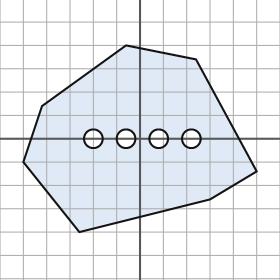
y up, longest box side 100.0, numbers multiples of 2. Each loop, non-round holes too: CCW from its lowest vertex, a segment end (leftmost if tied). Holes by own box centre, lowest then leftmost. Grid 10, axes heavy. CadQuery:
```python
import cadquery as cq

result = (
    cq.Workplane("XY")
    .moveTo(-26.0, -40.0)
    .lineTo(30.0, -26.0)
    .lineTo(50.0, -14.0)
    .lineTo(24.0, 34.0)
    .lineTo(-6.0, 40.0)
    .lineTo(-42.0, 14.0)
    .lineTo(-50.0, -10.0)
    .close()
    .moveTo(-20.0, 0.0)
    .circle(4.0)
    .moveTo(-6.0, 0.0)
    .circle(4.0)
    .moveTo(8.0, 0.0)
    .circle(4.0)
    .moveTo(22.0, 0.0)
    .circle(4.0)
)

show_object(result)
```